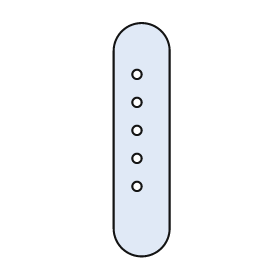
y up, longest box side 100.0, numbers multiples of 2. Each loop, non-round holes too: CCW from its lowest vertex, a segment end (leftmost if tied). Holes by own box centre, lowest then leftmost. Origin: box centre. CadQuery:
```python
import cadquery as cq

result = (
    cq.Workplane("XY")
    .moveTo(-12.0, -38.0)
    .threePointArc((0.0, -50.0), (12.0, -38.0))
    .lineTo(12.0, 38.0)
    .threePointArc((0.0, 50.0), (-12.0, 38.0))
    .close()
    .moveTo(-2.0, -20.0)
    .circle(2.0)
    .moveTo(-2.0, -8.0)
    .circle(2.0)
    .moveTo(-2.0, 4.0)
    .circle(2.0)
    .moveTo(-2.0, 16.0)
    .circle(2.0)
    .moveTo(-2.0, 28.0)
    .circle(2.0)
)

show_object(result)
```